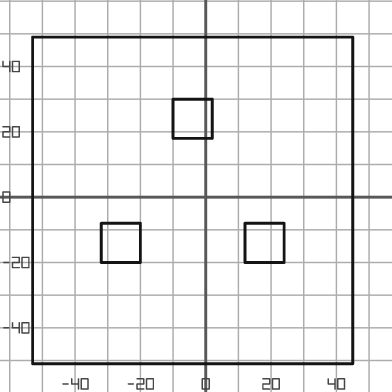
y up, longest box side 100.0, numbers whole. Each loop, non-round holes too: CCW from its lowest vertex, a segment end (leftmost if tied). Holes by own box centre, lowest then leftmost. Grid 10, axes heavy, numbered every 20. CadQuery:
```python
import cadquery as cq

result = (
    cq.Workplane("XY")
    .moveTo(-53.0, -51.0)
    .lineTo(45.0, -51.0)
    .lineTo(45.0, 49.0)
    .lineTo(-53.0, 49.0)
    .close()
    .moveTo(-32.0, -20.0)
    .lineTo(-20.0, -20.0)
    .lineTo(-20.0, -8.0)
    .lineTo(-32.0, -8.0)
    .close()
    .moveTo(12.0, -20.0)
    .lineTo(24.0, -20.0)
    .lineTo(24.0, -8.0)
    .lineTo(12.0, -8.0)
    .close()
    .moveTo(-10.0, 18.0)
    .lineTo(2.0, 18.0)
    .lineTo(2.0, 30.0)
    .lineTo(-10.0, 30.0)
    .close()
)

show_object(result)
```